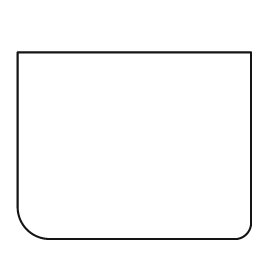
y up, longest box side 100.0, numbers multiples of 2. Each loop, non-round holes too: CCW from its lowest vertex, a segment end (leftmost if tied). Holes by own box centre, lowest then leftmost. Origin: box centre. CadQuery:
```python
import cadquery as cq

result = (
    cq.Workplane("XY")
    .moveTo(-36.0, -40.0)
    .lineTo(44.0, -40.0)
    .threePointArc((48.0, -38.0), (50.0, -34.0))
    .lineTo(50.0, 40.0)
    .lineTo(-50.0, 40.0)
    .lineTo(-50.0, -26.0)
    .threePointArc((-46.0, -36.0), (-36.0, -40.0))
    .close()
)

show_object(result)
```